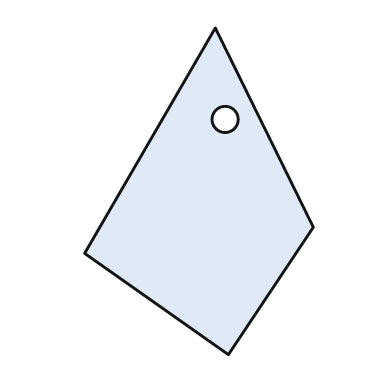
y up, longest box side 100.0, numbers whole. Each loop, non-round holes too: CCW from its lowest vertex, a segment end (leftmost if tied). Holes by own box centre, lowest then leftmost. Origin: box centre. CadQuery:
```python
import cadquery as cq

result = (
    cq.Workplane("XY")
    .moveTo(9.0, -50.0)
    .lineTo(35.0, -11.0)
    .lineTo(5.0, 50.0)
    .lineTo(-35.0, -19.0)
    .close()
    .moveTo(8.0, 22.0)
    .circle(4.0)
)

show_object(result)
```